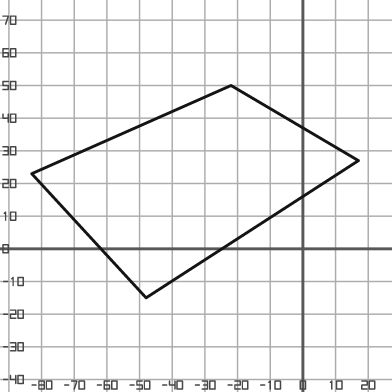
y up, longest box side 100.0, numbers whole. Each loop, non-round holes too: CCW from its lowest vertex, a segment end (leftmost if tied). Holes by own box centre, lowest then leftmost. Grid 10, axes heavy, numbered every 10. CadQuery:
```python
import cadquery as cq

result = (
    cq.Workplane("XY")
    .moveTo(-48.0, -15.0)
    .lineTo(17.0, 27.0)
    .lineTo(-22.0, 50.0)
    .lineTo(-83.0, 23.0)
    .close()
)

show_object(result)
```